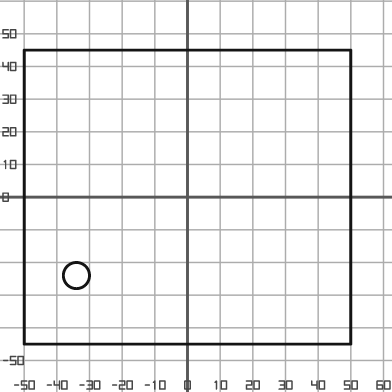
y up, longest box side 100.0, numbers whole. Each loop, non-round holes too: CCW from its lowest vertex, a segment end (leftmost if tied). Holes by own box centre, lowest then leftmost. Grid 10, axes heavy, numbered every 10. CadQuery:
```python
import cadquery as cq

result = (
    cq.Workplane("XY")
    .moveTo(-50.0, -45.0)
    .lineTo(50.0, -45.0)
    .lineTo(50.0, 45.0)
    .lineTo(-50.0, 45.0)
    .close()
    .moveTo(-34.0, -24.0)
    .circle(4.0)
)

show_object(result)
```